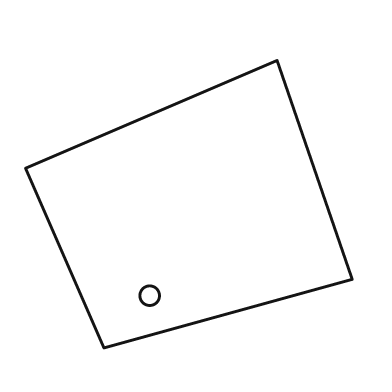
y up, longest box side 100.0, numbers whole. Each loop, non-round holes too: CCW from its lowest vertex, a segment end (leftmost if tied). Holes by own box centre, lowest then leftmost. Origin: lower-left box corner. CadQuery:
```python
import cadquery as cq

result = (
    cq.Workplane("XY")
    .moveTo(24.0, 0.0)
    .lineTo(100.0, 21.0)
    .lineTo(77.0, 88.0)
    .lineTo(0.0, 55.0)
    .close()
    .moveTo(38.0, 16.0)
    .circle(3.0)
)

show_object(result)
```